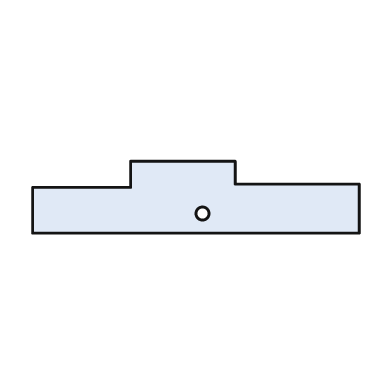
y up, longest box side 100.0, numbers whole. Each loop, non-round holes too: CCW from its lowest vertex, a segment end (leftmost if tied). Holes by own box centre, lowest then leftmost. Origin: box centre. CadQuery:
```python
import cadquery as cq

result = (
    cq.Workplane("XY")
    .moveTo(-50.0, -11.0)
    .lineTo(50.0, -11.0)
    .lineTo(50.0, 4.0)
    .lineTo(12.0, 4.0)
    .lineTo(12.0, 11.0)
    .lineTo(-20.0, 11.0)
    .lineTo(-20.0, 3.0)
    .lineTo(-50.0, 3.0)
    .close()
    .moveTo(2.0, -5.0)
    .circle(2.0)
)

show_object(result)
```